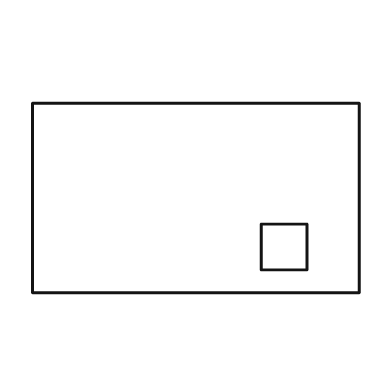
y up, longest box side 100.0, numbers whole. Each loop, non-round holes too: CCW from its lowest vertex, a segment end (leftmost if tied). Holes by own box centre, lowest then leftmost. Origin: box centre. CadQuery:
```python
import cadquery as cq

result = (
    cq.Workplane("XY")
    .moveTo(-50.0, -29.0)
    .lineTo(50.0, -29.0)
    .lineTo(50.0, 29.0)
    .lineTo(-50.0, 29.0)
    .close()
    .moveTo(20.0, -22.0)
    .lineTo(34.0, -22.0)
    .lineTo(34.0, -8.0)
    .lineTo(20.0, -8.0)
    .close()
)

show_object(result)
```